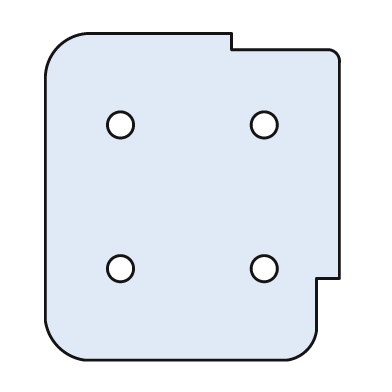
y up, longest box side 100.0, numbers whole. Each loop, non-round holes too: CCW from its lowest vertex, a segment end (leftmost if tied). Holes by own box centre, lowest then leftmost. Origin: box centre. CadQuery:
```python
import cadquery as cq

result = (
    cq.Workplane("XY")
    .moveTo(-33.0, -50.0)
    .lineTo(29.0, -50.0)
    .threePointArc((35.0, -47.0), (38.0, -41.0))
    .lineTo(38.0, -25.0)
    .lineTo(45.0, -25.0)
    .lineTo(45.0, 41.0)
    .threePointArc((44.0, 44.0), (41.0, 45.0))
    .lineTo(12.0, 45.0)
    .lineTo(12.0, 50.0)
    .lineTo(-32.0, 50.0)
    .threePointArc((-41.0, 46.0), (-45.0, 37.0))
    .lineTo(-45.0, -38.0)
    .threePointArc((-41.0, -46.0), (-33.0, -50.0))
    .close()
    .moveTo(-22.0, -22.0)
    .circle(4.0)
    .moveTo(22.0, -22.0)
    .circle(4.0)
    .moveTo(-22.0, 22.0)
    .circle(4.0)
    .moveTo(22.0, 22.0)
    .circle(4.0)
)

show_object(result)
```